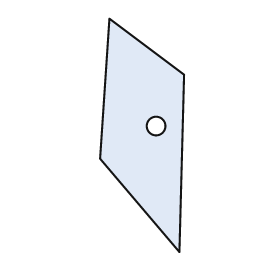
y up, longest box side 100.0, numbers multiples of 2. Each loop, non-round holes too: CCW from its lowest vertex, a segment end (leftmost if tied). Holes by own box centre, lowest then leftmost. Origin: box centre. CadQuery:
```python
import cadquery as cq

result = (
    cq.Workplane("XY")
    .moveTo(16.0, -50.0)
    .lineTo(18.0, 26.0)
    .lineTo(-14.0, 50.0)
    .lineTo(-18.0, -10.0)
    .close()
    .moveTo(6.0, 4.0)
    .circle(4.0)
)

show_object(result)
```